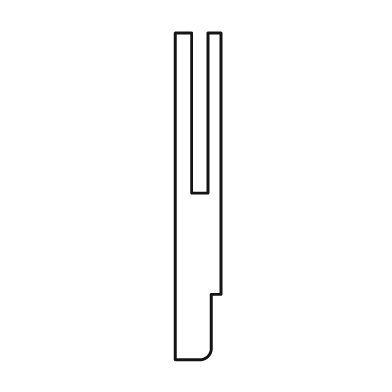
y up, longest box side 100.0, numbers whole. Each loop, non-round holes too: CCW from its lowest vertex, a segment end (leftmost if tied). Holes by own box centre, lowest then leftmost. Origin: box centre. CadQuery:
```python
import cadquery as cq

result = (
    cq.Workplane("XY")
    .moveTo(-7.0, -50.0)
    .lineTo(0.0, -50.0)
    .threePointArc((3.0, -49.0), (4.0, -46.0))
    .lineTo(4.0, -30.0)
    .lineTo(7.0, -30.0)
    .lineTo(7.0, 50.0)
    .lineTo(3.0, 50.0)
    .lineTo(3.0, 1.0)
    .lineTo(-2.0, 1.0)
    .lineTo(-2.0, 50.0)
    .lineTo(-7.0, 50.0)
    .close()
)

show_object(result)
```